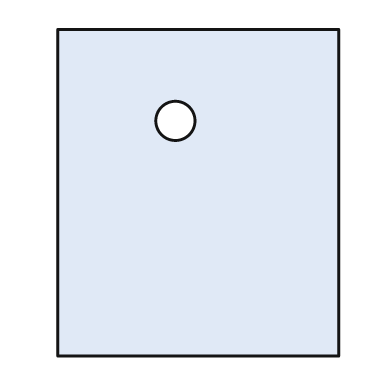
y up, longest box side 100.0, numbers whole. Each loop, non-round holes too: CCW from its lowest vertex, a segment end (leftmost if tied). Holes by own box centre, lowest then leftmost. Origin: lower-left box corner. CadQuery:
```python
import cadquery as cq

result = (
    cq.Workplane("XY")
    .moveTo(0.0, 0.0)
    .lineTo(86.0, 0.0)
    .lineTo(86.0, 100.0)
    .lineTo(0.0, 100.0)
    .close()
    .moveTo(36.0, 72.0)
    .circle(6.0)
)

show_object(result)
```